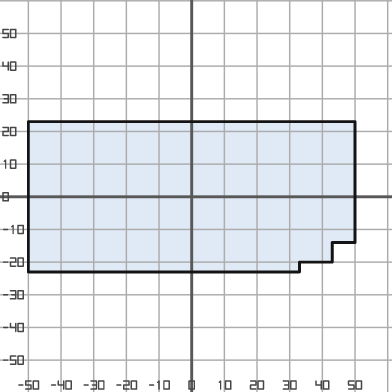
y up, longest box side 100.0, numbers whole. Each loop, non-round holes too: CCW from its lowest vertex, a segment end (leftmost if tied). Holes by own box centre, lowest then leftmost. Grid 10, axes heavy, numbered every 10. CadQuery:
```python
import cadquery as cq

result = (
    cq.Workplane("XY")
    .moveTo(-50.0, -23.0)
    .lineTo(33.0, -23.0)
    .lineTo(33.0, -20.0)
    .lineTo(43.0, -20.0)
    .lineTo(43.0, -14.0)
    .lineTo(50.0, -14.0)
    .lineTo(50.0, 23.0)
    .lineTo(-50.0, 23.0)
    .close()
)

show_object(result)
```